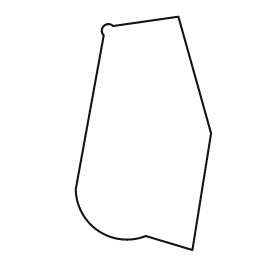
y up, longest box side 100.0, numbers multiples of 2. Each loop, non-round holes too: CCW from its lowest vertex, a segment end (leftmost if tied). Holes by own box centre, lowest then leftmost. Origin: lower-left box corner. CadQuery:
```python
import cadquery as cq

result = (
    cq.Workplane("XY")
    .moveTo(50.0, 0.0)
    .lineTo(58.0, 50.0)
    .lineTo(44.0, 100.0)
    .lineTo(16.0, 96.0)
    .threePointArc((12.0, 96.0), (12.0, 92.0))
    .lineTo(0.0, 26.0)
    .threePointArc((10.0, 8.0), (30.0, 6.0))
    .close()
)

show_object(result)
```